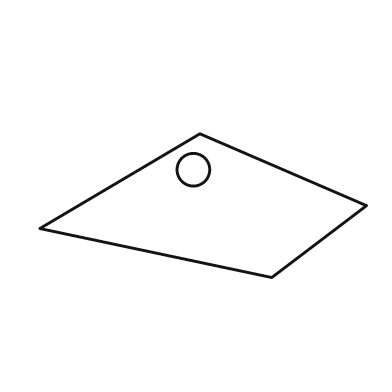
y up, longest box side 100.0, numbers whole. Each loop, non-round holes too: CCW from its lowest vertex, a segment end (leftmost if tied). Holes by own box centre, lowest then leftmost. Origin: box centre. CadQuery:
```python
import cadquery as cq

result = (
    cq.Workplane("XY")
    .moveTo(21.0, -22.0)
    .lineTo(50.0, 0.0)
    .lineTo(-1.0, 22.0)
    .lineTo(-50.0, -7.0)
    .close()
    .moveTo(-3.0, 11.0)
    .circle(5.0)
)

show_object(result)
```